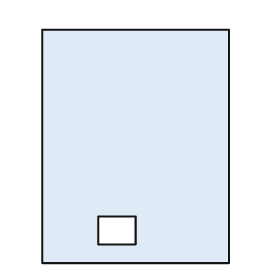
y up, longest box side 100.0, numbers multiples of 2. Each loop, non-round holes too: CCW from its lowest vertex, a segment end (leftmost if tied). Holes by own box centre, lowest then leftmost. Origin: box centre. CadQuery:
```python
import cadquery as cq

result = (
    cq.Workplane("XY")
    .moveTo(-40.0, -50.0)
    .lineTo(40.0, -50.0)
    .lineTo(40.0, 50.0)
    .lineTo(-40.0, 50.0)
    .close()
    .moveTo(-16.0, -42.0)
    .lineTo(0.0, -42.0)
    .lineTo(0.0, -30.0)
    .lineTo(-16.0, -30.0)
    .close()
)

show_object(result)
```